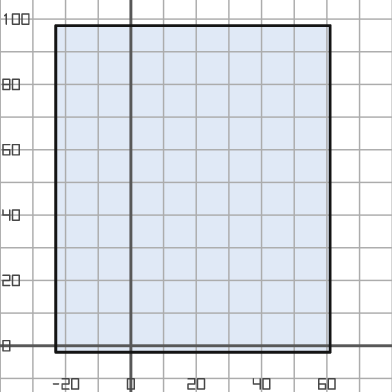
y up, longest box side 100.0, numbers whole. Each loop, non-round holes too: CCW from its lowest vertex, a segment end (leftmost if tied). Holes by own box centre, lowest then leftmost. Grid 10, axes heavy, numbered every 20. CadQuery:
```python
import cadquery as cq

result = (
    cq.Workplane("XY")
    .moveTo(-23.0, -2.0)
    .lineTo(61.0, -2.0)
    .lineTo(61.0, 98.0)
    .lineTo(-23.0, 98.0)
    .close()
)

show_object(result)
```